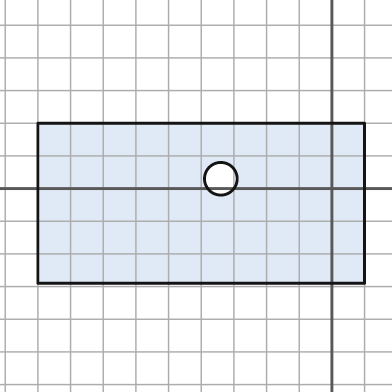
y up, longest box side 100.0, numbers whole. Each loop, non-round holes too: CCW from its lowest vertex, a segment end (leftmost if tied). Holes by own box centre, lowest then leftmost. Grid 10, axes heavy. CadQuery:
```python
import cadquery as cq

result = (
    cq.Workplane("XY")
    .moveTo(-90.0, -29.0)
    .lineTo(10.0, -29.0)
    .lineTo(10.0, 20.0)
    .lineTo(-90.0, 20.0)
    .close()
    .moveTo(-34.0, 3.0)
    .circle(5.0)
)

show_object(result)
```